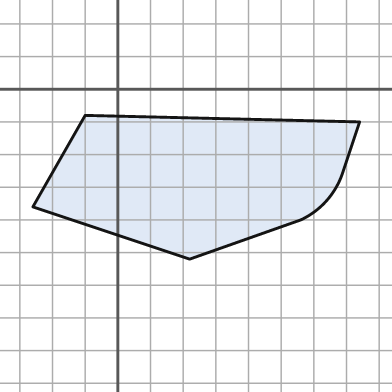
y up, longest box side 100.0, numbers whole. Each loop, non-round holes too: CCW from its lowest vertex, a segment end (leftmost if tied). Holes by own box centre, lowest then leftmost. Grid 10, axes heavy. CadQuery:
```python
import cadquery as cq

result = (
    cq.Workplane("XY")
    .moveTo(22.0, -52.0)
    .lineTo(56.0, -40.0)
    .threePointArc((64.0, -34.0), (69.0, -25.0))
    .lineTo(74.0, -10.0)
    .lineTo(-10.0, -8.0)
    .lineTo(-26.0, -36.0)
    .close()
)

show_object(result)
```